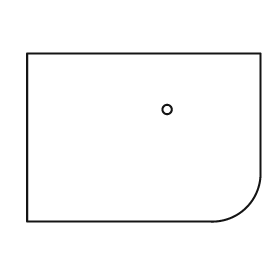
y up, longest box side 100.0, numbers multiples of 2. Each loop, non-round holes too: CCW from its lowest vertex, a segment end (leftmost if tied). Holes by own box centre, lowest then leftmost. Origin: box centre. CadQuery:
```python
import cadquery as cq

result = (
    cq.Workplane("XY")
    .moveTo(-50.0, -36.0)
    .lineTo(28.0, -36.0)
    .threePointArc((44.0, -30.0), (50.0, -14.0))
    .lineTo(50.0, 36.0)
    .lineTo(-50.0, 36.0)
    .close()
    .moveTo(10.0, 12.0)
    .circle(2.0)
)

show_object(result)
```